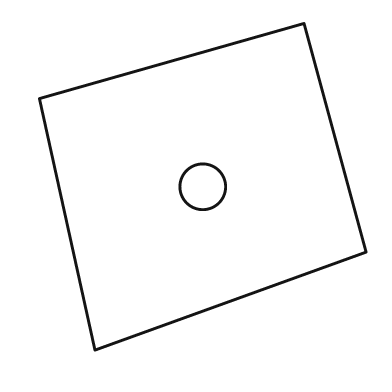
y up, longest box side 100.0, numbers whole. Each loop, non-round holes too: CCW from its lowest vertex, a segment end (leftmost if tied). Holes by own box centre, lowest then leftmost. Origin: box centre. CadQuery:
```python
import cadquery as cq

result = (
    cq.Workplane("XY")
    .moveTo(-33.0, -50.0)
    .lineTo(50.0, -20.0)
    .lineTo(31.0, 50.0)
    .lineTo(-50.0, 27.0)
    .close()
    .moveTo(0.0, 0.0)
    .circle(7.0)
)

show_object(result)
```